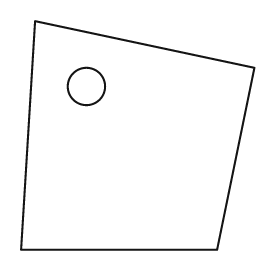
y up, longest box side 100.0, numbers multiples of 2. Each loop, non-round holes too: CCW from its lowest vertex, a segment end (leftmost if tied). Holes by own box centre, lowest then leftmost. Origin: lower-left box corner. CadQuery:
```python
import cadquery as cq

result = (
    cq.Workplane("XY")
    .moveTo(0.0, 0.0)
    .lineTo(84.0, 0.0)
    .lineTo(100.0, 78.0)
    .lineTo(6.0, 98.0)
    .close()
    .moveTo(28.0, 70.0)
    .circle(8.0)
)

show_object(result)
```